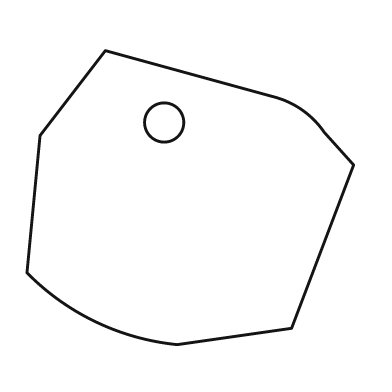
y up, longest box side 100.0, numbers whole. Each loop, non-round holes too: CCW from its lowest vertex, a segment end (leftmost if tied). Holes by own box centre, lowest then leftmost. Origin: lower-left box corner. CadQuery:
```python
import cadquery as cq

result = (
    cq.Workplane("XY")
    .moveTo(46.0, 0.0)
    .lineTo(81.0, 5.0)
    .lineTo(100.0, 55.0)
    .lineTo(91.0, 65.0)
    .threePointArc((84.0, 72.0), (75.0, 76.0))
    .lineTo(24.0, 90.0)
    .lineTo(4.0, 64.0)
    .lineTo(0.0, 22.0)
    .threePointArc((21.0, 7.0), (46.0, 0.0))
    .close()
    .moveTo(42.0, 68.0)
    .circle(6.0)
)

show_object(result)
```